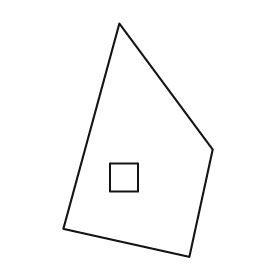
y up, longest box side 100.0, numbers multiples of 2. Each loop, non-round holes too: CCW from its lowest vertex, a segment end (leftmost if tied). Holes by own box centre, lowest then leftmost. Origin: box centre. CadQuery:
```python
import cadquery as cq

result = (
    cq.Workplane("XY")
    .moveTo(22.0, -50.0)
    .lineTo(32.0, -4.0)
    .lineTo(-8.0, 50.0)
    .lineTo(-32.0, -38.0)
    .close()
    .moveTo(-12.0, -22.0)
    .lineTo(0.0, -22.0)
    .lineTo(0.0, -10.0)
    .lineTo(-12.0, -10.0)
    .close()
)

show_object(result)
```